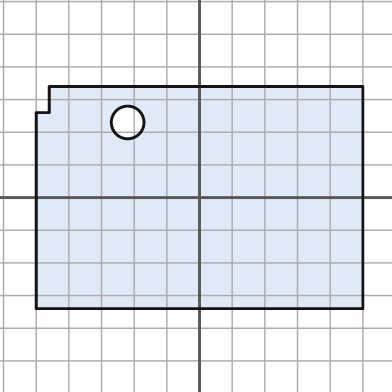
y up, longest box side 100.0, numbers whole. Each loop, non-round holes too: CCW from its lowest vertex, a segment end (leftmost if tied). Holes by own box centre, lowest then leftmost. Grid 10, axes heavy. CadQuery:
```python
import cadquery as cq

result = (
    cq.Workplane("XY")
    .moveTo(-50.0, -34.0)
    .lineTo(50.0, -34.0)
    .lineTo(50.0, 34.0)
    .lineTo(-46.0, 34.0)
    .lineTo(-46.0, 26.0)
    .lineTo(-50.0, 26.0)
    .close()
    .moveTo(-22.0, 23.0)
    .circle(5.0)
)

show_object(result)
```